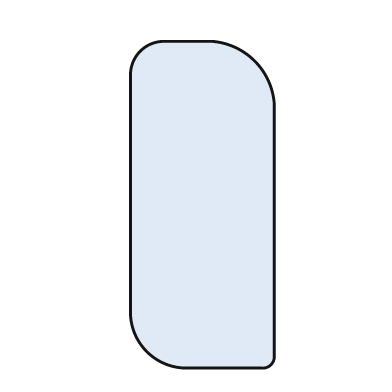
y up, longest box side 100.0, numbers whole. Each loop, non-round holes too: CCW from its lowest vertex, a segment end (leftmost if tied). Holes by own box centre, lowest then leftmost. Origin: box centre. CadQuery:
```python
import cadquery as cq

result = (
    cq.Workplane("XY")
    .moveTo(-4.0, -50.0)
    .lineTo(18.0, -50.0)
    .threePointArc((21.0, -49.0), (22.0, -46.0))
    .lineTo(22.0, 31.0)
    .threePointArc((16.0, 44.0), (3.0, 50.0))
    .lineTo(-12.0, 50.0)
    .threePointArc((-19.0, 47.0), (-22.0, 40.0))
    .lineTo(-22.0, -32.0)
    .threePointArc((-17.0, -45.0), (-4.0, -50.0))
    .close()
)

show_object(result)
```